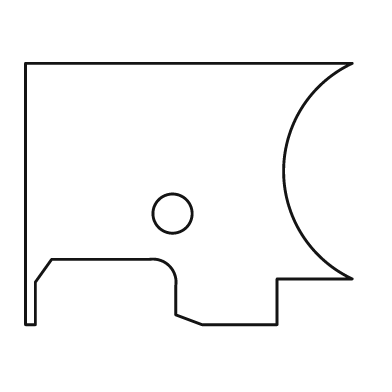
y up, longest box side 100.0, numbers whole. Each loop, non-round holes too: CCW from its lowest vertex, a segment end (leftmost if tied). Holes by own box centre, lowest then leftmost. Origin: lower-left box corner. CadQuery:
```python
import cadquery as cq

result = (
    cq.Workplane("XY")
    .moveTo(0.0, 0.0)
    .lineTo(3.0, 0.0)
    .lineTo(3.0, 13.0)
    .lineTo(8.0, 20.0)
    .lineTo(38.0, 20.0)
    .threePointArc((44.0, 18.0), (46.0, 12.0))
    .lineTo(46.0, 3.0)
    .lineTo(54.0, 0.0)
    .lineTo(77.0, 0.0)
    .lineTo(77.0, 14.0)
    .lineTo(100.0, 14.0)
    .threePointArc((79.0, 47.0), (100.0, 80.0))
    .lineTo(0.0, 80.0)
    .close()
    .moveTo(45.0, 34.0)
    .circle(6.0)
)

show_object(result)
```